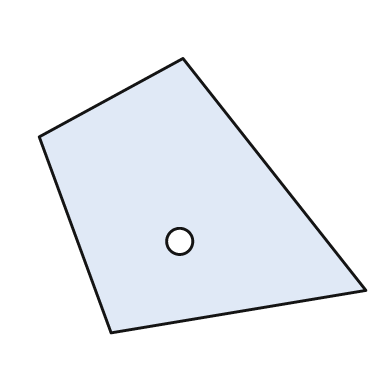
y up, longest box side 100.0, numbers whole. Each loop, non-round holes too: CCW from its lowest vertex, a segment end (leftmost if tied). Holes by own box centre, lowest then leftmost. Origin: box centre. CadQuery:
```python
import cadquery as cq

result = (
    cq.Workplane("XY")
    .moveTo(-28.0, -42.0)
    .lineTo(50.0, -29.0)
    .lineTo(-6.0, 42.0)
    .lineTo(-50.0, 18.0)
    .close()
    .moveTo(-7.0, -14.0)
    .circle(4.0)
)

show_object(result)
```